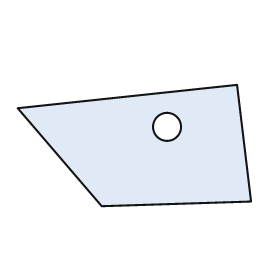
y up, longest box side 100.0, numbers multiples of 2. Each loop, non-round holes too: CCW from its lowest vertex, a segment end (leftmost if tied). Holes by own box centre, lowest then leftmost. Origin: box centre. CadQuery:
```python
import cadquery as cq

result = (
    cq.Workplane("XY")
    .moveTo(-14.0, -26.0)
    .lineTo(50.0, -24.0)
    .lineTo(44.0, 26.0)
    .lineTo(-50.0, 16.0)
    .close()
    .moveTo(14.0, 8.0)
    .circle(6.0)
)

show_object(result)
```